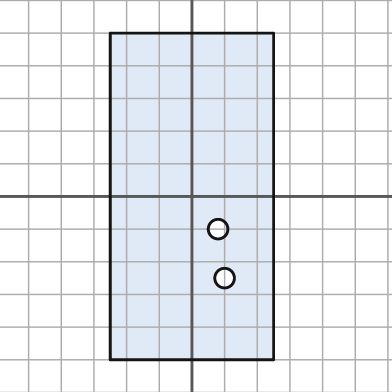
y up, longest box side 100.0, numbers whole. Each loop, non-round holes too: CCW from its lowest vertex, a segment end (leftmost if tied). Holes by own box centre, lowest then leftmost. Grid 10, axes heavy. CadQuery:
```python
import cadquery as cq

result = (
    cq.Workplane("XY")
    .moveTo(-25.0, -50.0)
    .lineTo(25.0, -50.0)
    .lineTo(25.0, 50.0)
    .lineTo(-25.0, 50.0)
    .close()
    .moveTo(10.0, -25.0)
    .circle(3.0)
    .moveTo(8.0, -10.0)
    .circle(3.0)
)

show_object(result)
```